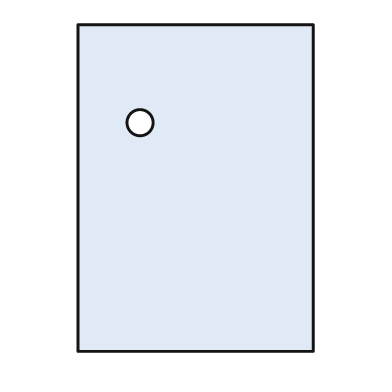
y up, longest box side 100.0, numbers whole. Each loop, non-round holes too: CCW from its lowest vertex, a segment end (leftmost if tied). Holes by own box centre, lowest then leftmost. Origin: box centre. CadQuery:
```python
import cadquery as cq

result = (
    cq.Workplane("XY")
    .moveTo(-36.0, -50.0)
    .lineTo(36.0, -50.0)
    .lineTo(36.0, 50.0)
    .lineTo(-36.0, 50.0)
    .close()
    .moveTo(-17.0, 20.0)
    .circle(4.0)
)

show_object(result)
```